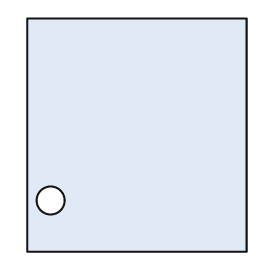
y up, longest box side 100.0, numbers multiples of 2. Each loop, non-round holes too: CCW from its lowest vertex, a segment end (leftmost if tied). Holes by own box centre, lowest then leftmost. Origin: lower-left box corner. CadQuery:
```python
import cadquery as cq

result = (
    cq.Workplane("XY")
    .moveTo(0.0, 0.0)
    .lineTo(94.0, 0.0)
    .lineTo(94.0, 100.0)
    .lineTo(0.0, 100.0)
    .close()
    .moveTo(10.0, 22.0)
    .circle(6.0)
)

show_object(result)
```